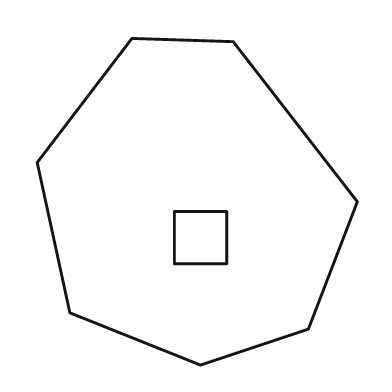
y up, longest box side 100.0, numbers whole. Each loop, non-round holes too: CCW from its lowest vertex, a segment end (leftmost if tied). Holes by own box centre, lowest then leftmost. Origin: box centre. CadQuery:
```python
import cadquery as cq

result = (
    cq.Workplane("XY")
    .moveTo(1.0, -50.0)
    .lineTo(34.0, -39.0)
    .lineTo(49.0, 0.0)
    .lineTo(11.0, 49.0)
    .lineTo(-20.0, 50.0)
    .lineTo(-49.0, 12.0)
    .lineTo(-39.0, -34.0)
    .close()
    .moveTo(-7.0, -19.0)
    .lineTo(9.0, -19.0)
    .lineTo(9.0, -3.0)
    .lineTo(-7.0, -3.0)
    .close()
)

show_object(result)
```